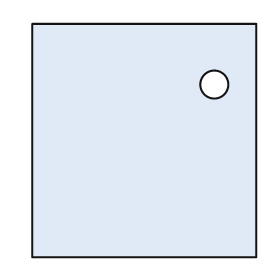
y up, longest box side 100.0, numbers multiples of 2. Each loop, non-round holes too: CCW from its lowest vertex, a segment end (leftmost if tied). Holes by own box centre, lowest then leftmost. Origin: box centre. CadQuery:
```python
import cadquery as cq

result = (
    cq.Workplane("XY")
    .moveTo(-48.0, -50.0)
    .lineTo(48.0, -50.0)
    .lineTo(48.0, 50.0)
    .lineTo(-48.0, 50.0)
    .close()
    .moveTo(30.0, 24.0)
    .circle(6.0)
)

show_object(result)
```